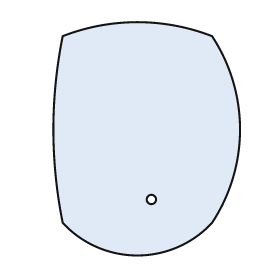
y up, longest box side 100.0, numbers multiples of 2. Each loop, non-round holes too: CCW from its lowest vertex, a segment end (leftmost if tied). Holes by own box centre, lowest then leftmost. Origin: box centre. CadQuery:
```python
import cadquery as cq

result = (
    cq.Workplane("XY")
    .moveTo(-36.0, -36.0)
    .threePointArc((-4.0, -50.0), (28.0, -36.0))
    .threePointArc((40.0, 4.0), (28.0, 44.0))
    .threePointArc((-4.0, 50.0), (-36.0, 44.0))
    .threePointArc((-40.0, 4.0), (-36.0, -36.0))
    .close()
    .moveTo(2.0, -26.0)
    .circle(2.0)
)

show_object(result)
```